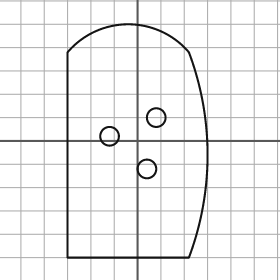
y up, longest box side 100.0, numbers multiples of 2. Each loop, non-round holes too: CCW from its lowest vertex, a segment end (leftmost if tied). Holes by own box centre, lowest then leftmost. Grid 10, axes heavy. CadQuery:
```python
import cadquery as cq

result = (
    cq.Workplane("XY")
    .moveTo(-30.0, -50.0)
    .lineTo(22.0, -50.0)
    .threePointArc((30.0, -6.0), (22.0, 38.0))
    .threePointArc((-4.0, 50.0), (-30.0, 38.0))
    .close()
    .moveTo(4.0, -12.0)
    .circle(4.0)
    .moveTo(-12.0, 2.0)
    .circle(4.0)
    .moveTo(8.0, 10.0)
    .circle(4.0)
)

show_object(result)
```